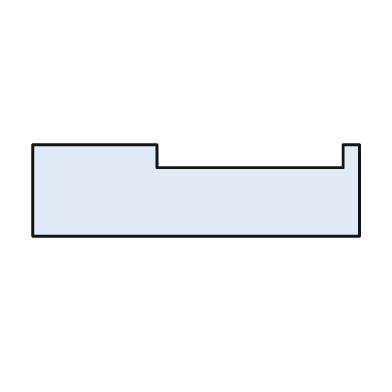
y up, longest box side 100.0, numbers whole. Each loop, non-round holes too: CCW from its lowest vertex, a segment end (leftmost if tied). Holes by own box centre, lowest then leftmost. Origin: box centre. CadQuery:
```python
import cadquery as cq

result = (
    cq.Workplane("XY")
    .moveTo(-50.0, -14.0)
    .lineTo(50.0, -14.0)
    .lineTo(50.0, 14.0)
    .lineTo(45.0, 14.0)
    .lineTo(45.0, 7.0)
    .lineTo(-12.0, 7.0)
    .lineTo(-12.0, 14.0)
    .lineTo(-50.0, 14.0)
    .close()
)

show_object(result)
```